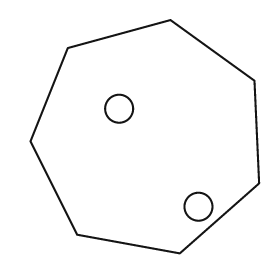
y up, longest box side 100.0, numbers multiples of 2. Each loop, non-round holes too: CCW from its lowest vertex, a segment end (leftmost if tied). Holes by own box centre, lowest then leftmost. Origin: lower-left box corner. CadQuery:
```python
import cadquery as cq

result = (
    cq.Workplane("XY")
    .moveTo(64.0, 0.0)
    .lineTo(98.0, 30.0)
    .lineTo(96.0, 74.0)
    .lineTo(60.0, 100.0)
    .lineTo(16.0, 88.0)
    .lineTo(0.0, 48.0)
    .lineTo(20.0, 8.0)
    .close()
    .moveTo(72.0, 20.0)
    .circle(6.0)
    .moveTo(38.0, 62.0)
    .circle(6.0)
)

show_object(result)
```